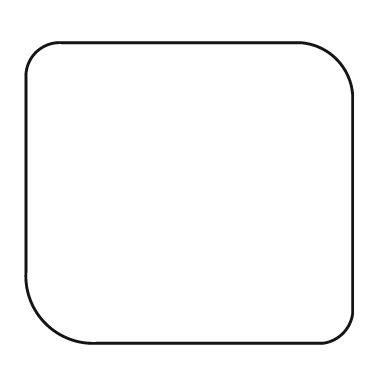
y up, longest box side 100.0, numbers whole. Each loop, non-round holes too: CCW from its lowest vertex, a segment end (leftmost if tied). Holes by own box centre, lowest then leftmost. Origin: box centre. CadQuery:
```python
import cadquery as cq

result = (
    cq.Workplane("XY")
    .moveTo(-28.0, -46.0)
    .lineTo(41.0, -46.0)
    .threePointArc((47.0, -43.0), (50.0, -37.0))
    .lineTo(50.0, 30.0)
    .threePointArc((45.0, 41.0), (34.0, 46.0))
    .lineTo(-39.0, 46.0)
    .threePointArc((-47.0, 43.0), (-50.0, 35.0))
    .lineTo(-50.0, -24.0)
    .threePointArc((-44.0, -40.0), (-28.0, -46.0))
    .close()
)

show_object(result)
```